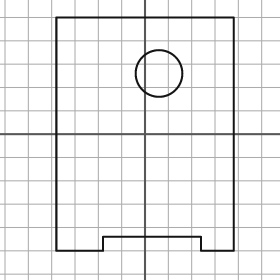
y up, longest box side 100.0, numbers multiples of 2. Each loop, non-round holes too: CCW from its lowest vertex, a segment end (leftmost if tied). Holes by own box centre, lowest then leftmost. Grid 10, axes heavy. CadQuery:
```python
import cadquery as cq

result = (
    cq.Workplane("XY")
    .moveTo(-38.0, -50.0)
    .lineTo(-18.0, -50.0)
    .lineTo(-18.0, -44.0)
    .lineTo(24.0, -44.0)
    .lineTo(24.0, -50.0)
    .lineTo(38.0, -50.0)
    .lineTo(38.0, 50.0)
    .lineTo(-38.0, 50.0)
    .close()
    .moveTo(6.0, 26.0)
    .circle(10.0)
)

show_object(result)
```